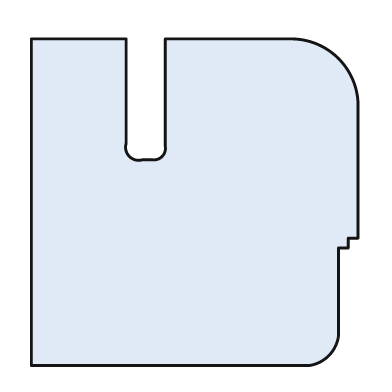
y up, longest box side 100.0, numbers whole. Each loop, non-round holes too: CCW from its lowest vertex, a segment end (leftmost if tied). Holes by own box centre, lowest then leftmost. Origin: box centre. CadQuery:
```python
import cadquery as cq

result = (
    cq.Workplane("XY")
    .moveTo(-50.0, -50.0)
    .lineTo(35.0, -50.0)
    .threePointArc((41.0, -47.0), (44.0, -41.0))
    .lineTo(44.0, -14.0)
    .lineTo(47.0, -14.0)
    .lineTo(47.0, -11.0)
    .lineTo(50.0, -11.0)
    .lineTo(50.0, 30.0)
    .threePointArc((44.0, 44.0), (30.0, 50.0))
    .lineTo(-9.0, 50.0)
    .lineTo(-9.0, 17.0)
    .threePointArc((-10.0, 14.0), (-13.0, 13.0))
    .lineTo(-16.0, 13.0)
    .threePointArc((-20.0, 14.0), (-21.0, 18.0))
    .lineTo(-21.0, 50.0)
    .lineTo(-50.0, 50.0)
    .close()
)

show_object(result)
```